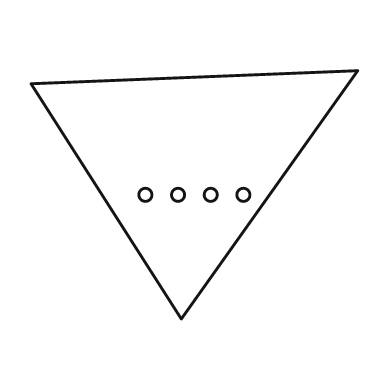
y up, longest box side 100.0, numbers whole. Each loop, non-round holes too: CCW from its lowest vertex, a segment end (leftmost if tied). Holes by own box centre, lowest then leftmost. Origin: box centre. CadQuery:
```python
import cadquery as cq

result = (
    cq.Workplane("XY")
    .moveTo(-4.0, -38.0)
    .lineTo(50.0, 38.0)
    .lineTo(-50.0, 34.0)
    .close()
    .moveTo(-15.0, 0.0)
    .circle(2.0)
    .moveTo(-5.0, 0.0)
    .circle(2.0)
    .moveTo(5.0, 0.0)
    .circle(2.0)
    .moveTo(15.0, 0.0)
    .circle(2.0)
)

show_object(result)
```